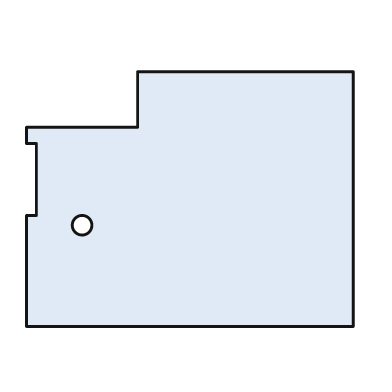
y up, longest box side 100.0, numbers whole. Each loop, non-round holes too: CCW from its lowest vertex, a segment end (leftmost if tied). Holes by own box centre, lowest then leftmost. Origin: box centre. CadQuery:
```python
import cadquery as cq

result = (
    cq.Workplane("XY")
    .moveTo(-50.0, -39.0)
    .lineTo(50.0, -39.0)
    .lineTo(50.0, 39.0)
    .lineTo(-16.0, 39.0)
    .lineTo(-16.0, 22.0)
    .lineTo(-50.0, 22.0)
    .lineTo(-50.0, 17.0)
    .lineTo(-47.0, 17.0)
    .lineTo(-47.0, -5.0)
    .lineTo(-50.0, -5.0)
    .close()
    .moveTo(-33.0, -8.0)
    .circle(3.0)
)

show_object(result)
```